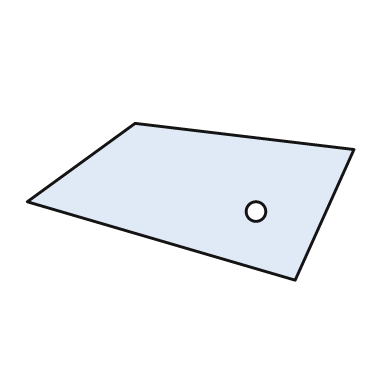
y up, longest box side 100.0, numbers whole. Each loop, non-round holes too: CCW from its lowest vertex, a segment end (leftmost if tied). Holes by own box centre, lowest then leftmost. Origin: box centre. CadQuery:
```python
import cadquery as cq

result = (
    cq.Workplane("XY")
    .moveTo(32.0, -24.0)
    .lineTo(50.0, 16.0)
    .lineTo(-17.0, 24.0)
    .lineTo(-50.0, 0.0)
    .close()
    .moveTo(20.0, -3.0)
    .circle(3.0)
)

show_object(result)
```